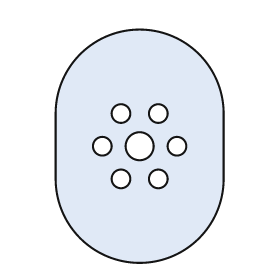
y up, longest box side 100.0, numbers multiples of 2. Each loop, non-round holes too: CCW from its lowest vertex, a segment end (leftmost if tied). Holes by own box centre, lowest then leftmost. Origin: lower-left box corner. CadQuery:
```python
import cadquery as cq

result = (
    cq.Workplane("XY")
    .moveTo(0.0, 36.0)
    .threePointArc((36.0, 0.0), (72.0, 36.0))
    .lineTo(72.0, 64.0)
    .threePointArc((36.0, 100.0), (0.0, 64.0))
    .close()
    .moveTo(28.0, 36.0)
    .circle(4.0)
    .moveTo(44.0, 36.0)
    .circle(4.0)
    .moveTo(20.0, 50.0)
    .circle(4.0)
    .moveTo(36.0, 50.0)
    .circle(6.0)
    .moveTo(52.0, 50.0)
    .circle(4.0)
    .moveTo(28.0, 64.0)
    .circle(4.0)
    .moveTo(44.0, 64.0)
    .circle(4.0)
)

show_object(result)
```